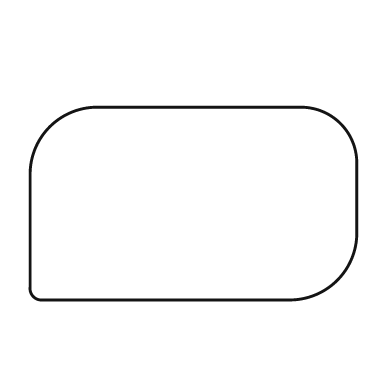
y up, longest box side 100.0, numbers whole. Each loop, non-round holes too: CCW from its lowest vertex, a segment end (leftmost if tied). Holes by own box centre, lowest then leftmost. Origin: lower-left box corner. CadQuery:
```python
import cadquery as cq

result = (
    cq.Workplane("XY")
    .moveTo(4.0, 0.0)
    .lineTo(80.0, 0.0)
    .threePointArc((94.0, 6.0), (100.0, 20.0))
    .lineTo(100.0, 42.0)
    .threePointArc((95.0, 54.0), (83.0, 59.0))
    .lineTo(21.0, 59.0)
    .threePointArc((6.0, 53.0), (0.0, 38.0))
    .lineTo(0.0, 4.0)
    .threePointArc((1.0, 1.0), (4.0, 0.0))
    .close()
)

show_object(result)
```